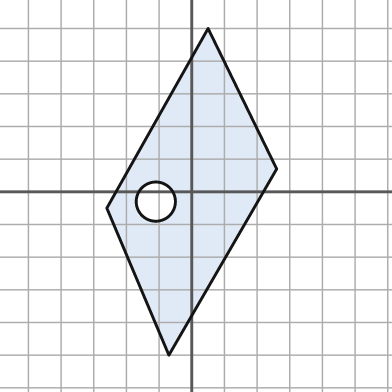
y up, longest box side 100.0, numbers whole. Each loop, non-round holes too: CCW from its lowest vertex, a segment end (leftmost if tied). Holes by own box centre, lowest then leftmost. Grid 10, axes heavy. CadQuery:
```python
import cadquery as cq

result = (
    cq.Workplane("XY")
    .moveTo(-7.0, -50.0)
    .lineTo(26.0, 7.0)
    .lineTo(5.0, 50.0)
    .lineTo(-26.0, -5.0)
    .close()
    .moveTo(-11.0, -3.0)
    .circle(6.0)
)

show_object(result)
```